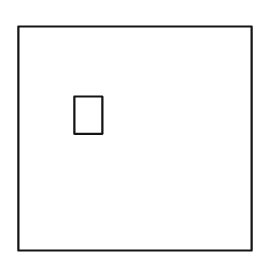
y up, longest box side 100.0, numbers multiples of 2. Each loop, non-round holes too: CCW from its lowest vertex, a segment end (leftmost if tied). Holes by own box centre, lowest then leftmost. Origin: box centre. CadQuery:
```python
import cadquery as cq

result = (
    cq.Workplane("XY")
    .moveTo(-50.0, -48.0)
    .lineTo(50.0, -48.0)
    .lineTo(50.0, 48.0)
    .lineTo(-50.0, 48.0)
    .close()
    .moveTo(-26.0, 2.0)
    .lineTo(-14.0, 2.0)
    .lineTo(-14.0, 18.0)
    .lineTo(-26.0, 18.0)
    .close()
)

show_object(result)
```